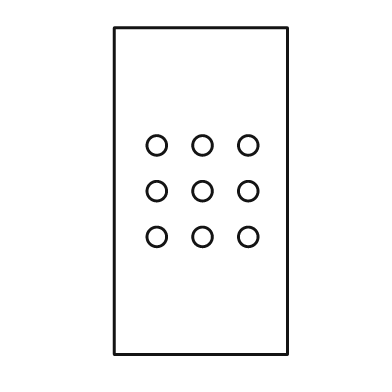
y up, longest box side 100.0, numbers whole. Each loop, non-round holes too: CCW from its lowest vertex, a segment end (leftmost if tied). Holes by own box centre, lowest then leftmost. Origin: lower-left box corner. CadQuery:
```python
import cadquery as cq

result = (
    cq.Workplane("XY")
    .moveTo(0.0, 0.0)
    .lineTo(53.0, 0.0)
    .lineTo(53.0, 100.0)
    .lineTo(0.0, 100.0)
    .close()
    .moveTo(13.0, 36.0)
    .circle(3.0)
    .moveTo(27.0, 36.0)
    .circle(3.0)
    .moveTo(41.0, 36.0)
    .circle(3.0)
    .moveTo(13.0, 50.0)
    .circle(3.0)
    .moveTo(27.0, 50.0)
    .circle(3.0)
    .moveTo(41.0, 50.0)
    .circle(3.0)
    .moveTo(13.0, 64.0)
    .circle(3.0)
    .moveTo(27.0, 64.0)
    .circle(3.0)
    .moveTo(41.0, 64.0)
    .circle(3.0)
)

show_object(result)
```